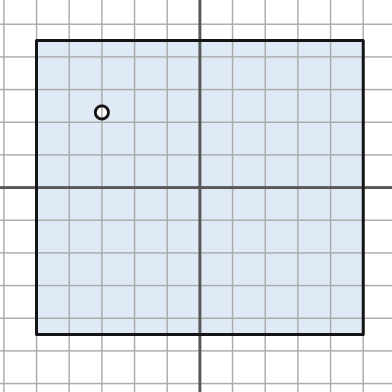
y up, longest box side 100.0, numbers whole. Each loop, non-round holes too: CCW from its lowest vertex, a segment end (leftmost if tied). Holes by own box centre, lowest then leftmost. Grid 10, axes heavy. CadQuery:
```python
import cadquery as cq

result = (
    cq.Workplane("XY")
    .moveTo(-50.0, -45.0)
    .lineTo(50.0, -45.0)
    .lineTo(50.0, 45.0)
    .lineTo(-50.0, 45.0)
    .close()
    .moveTo(-30.0, 23.0)
    .circle(2.0)
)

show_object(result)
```